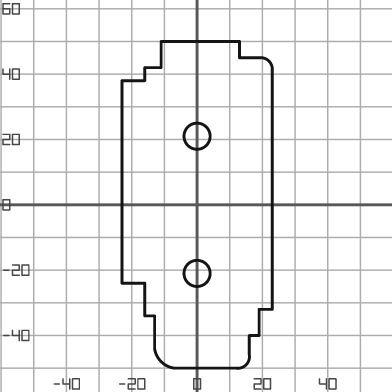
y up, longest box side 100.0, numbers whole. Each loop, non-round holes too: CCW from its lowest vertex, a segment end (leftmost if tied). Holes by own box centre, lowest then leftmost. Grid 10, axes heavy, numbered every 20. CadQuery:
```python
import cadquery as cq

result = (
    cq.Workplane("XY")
    .moveTo(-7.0, -50.0)
    .lineTo(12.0, -50.0)
    .threePointArc((15.0, -49.0), (16.0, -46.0))
    .lineTo(16.0, -40.0)
    .lineTo(19.0, -40.0)
    .lineTo(19.0, -32.0)
    .lineTo(23.0, -32.0)
    .lineTo(23.0, 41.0)
    .threePointArc((22.0, 44.0), (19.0, 45.0))
    .lineTo(13.0, 45.0)
    .lineTo(13.0, 50.0)
    .lineTo(-11.0, 50.0)
    .lineTo(-11.0, 42.0)
    .lineTo(-16.0, 42.0)
    .lineTo(-16.0, 38.0)
    .lineTo(-23.0, 38.0)
    .lineTo(-23.0, -24.0)
    .lineTo(-16.0, -24.0)
    .lineTo(-16.0, -34.0)
    .lineTo(-13.0, -34.0)
    .lineTo(-13.0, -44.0)
    .threePointArc((-11.0, -48.0), (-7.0, -50.0))
    .close()
    .moveTo(0.0, -21.0)
    .circle(4.0)
    .moveTo(0.0, 21.0)
    .circle(4.0)
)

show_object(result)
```